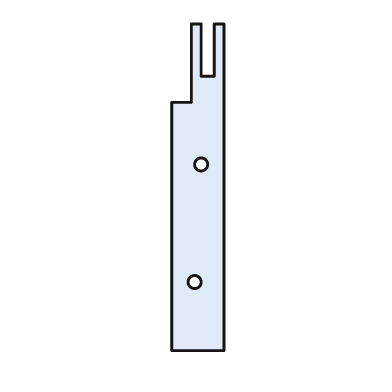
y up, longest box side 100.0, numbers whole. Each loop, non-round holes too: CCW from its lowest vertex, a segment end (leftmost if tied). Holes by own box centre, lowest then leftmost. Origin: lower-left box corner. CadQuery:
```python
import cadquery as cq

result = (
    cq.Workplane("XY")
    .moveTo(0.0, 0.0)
    .lineTo(16.0, 0.0)
    .lineTo(16.0, 100.0)
    .lineTo(13.0, 100.0)
    .lineTo(13.0, 84.0)
    .lineTo(9.0, 84.0)
    .lineTo(9.0, 100.0)
    .lineTo(6.0, 100.0)
    .lineTo(6.0, 76.0)
    .lineTo(0.0, 76.0)
    .close()
    .moveTo(7.0, 21.0)
    .circle(2.0)
    .moveTo(9.0, 57.0)
    .circle(2.0)
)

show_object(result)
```